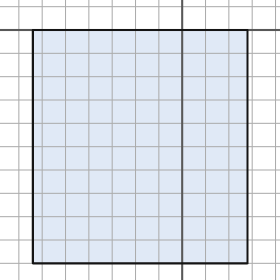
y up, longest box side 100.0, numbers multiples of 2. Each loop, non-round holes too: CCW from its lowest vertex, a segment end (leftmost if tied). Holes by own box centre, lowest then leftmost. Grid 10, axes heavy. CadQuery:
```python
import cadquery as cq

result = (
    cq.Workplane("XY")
    .moveTo(-64.0, -100.0)
    .lineTo(28.0, -100.0)
    .lineTo(28.0, 0.0)
    .lineTo(-64.0, 0.0)
    .close()
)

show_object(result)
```